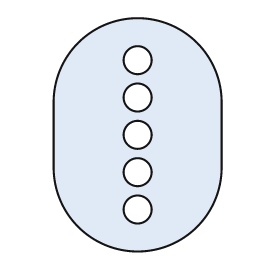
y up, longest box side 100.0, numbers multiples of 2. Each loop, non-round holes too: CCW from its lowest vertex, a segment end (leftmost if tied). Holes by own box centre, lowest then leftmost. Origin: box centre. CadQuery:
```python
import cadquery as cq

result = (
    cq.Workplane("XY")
    .moveTo(-36.0, -14.0)
    .threePointArc((0.0, -50.0), (36.0, -14.0))
    .lineTo(36.0, 14.0)
    .threePointArc((0.0, 50.0), (-36.0, 14.0))
    .close()
    .moveTo(0.0, -32.0)
    .circle(6.0)
    .moveTo(0.0, -16.0)
    .circle(6.0)
    .moveTo(0.0, 0.0)
    .circle(6.0)
    .moveTo(0.0, 16.0)
    .circle(6.0)
    .moveTo(0.0, 32.0)
    .circle(6.0)
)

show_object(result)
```